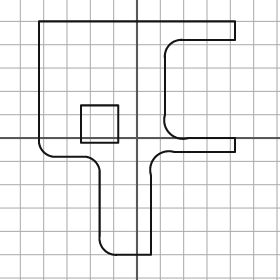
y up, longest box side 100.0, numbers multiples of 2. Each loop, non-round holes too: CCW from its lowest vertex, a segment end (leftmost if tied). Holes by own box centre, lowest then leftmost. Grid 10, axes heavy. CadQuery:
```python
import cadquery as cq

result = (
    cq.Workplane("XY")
    .moveTo(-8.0, -50.0)
    .lineTo(6.0, -50.0)
    .lineTo(6.0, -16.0)
    .threePointArc((8.0, -8.0), (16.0, -6.0))
    .lineTo(42.0, -6.0)
    .lineTo(42.0, 0.0)
    .lineTo(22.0, 0.0)
    .threePointArc((14.0, 2.0), (12.0, 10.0))
    .lineTo(12.0, 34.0)
    .threePointArc((14.0, 40.0), (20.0, 42.0))
    .lineTo(42.0, 42.0)
    .lineTo(42.0, 50.0)
    .lineTo(-42.0, 50.0)
    .lineTo(-42.0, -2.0)
    .threePointArc((-40.0, -6.0), (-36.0, -8.0))
    .lineTo(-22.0, -8.0)
    .threePointArc((-18.0, -10.0), (-16.0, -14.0))
    .lineTo(-16.0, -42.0)
    .threePointArc((-14.0, -48.0), (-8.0, -50.0))
    .close()
    .moveTo(-24.0, -2.0)
    .lineTo(-8.0, -2.0)
    .lineTo(-8.0, 14.0)
    .lineTo(-24.0, 14.0)
    .close()
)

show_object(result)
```